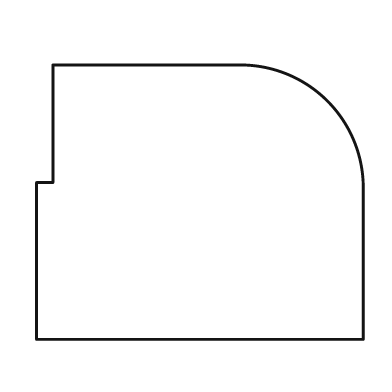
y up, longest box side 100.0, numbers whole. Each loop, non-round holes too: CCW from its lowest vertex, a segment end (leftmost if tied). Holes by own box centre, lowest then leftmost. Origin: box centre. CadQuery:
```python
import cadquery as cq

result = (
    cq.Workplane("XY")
    .moveTo(-50.0, -42.0)
    .lineTo(50.0, -42.0)
    .lineTo(50.0, 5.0)
    .threePointArc((39.0, 31.0), (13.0, 42.0))
    .lineTo(-45.0, 42.0)
    .lineTo(-45.0, 6.0)
    .lineTo(-50.0, 6.0)
    .close()
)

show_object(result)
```